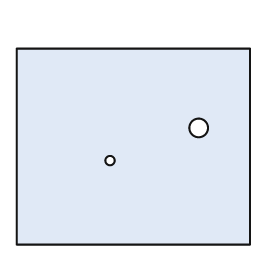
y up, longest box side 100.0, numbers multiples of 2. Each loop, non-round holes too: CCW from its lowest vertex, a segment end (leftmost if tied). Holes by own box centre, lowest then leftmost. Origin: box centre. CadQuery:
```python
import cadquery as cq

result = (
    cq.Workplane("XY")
    .moveTo(-50.0, -42.0)
    .lineTo(50.0, -42.0)
    .lineTo(50.0, 42.0)
    .lineTo(-50.0, 42.0)
    .close()
    .moveTo(-10.0, -6.0)
    .circle(2.0)
    .moveTo(28.0, 8.0)
    .circle(4.0)
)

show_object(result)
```